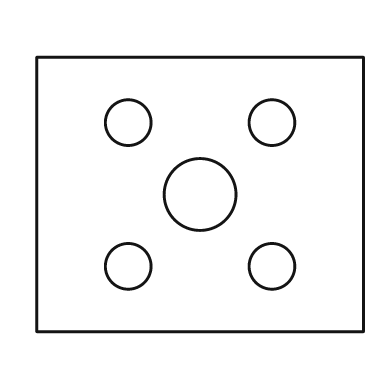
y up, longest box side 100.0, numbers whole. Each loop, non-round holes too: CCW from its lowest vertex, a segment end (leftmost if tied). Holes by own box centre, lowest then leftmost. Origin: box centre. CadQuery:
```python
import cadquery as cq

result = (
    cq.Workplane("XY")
    .moveTo(-50.0, -42.0)
    .lineTo(50.0, -42.0)
    .lineTo(50.0, 42.0)
    .lineTo(-50.0, 42.0)
    .close()
    .moveTo(-22.0, -22.0)
    .circle(7.0)
    .moveTo(22.0, -22.0)
    .circle(7.0)
    .moveTo(0.0, 0.0)
    .circle(11.0)
    .moveTo(-22.0, 22.0)
    .circle(7.0)
    .moveTo(22.0, 22.0)
    .circle(7.0)
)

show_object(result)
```